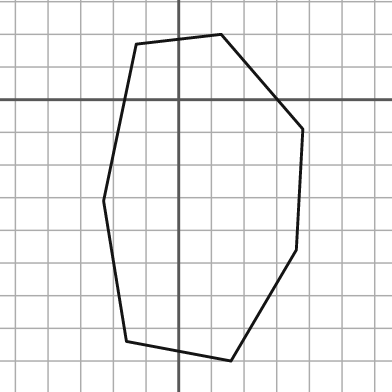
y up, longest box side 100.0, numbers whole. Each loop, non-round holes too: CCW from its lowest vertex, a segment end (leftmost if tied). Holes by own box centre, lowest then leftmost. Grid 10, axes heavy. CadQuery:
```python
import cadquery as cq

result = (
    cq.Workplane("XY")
    .moveTo(16.0, -80.0)
    .lineTo(36.0, -46.0)
    .lineTo(38.0, -9.0)
    .lineTo(13.0, 20.0)
    .lineTo(-13.0, 17.0)
    .lineTo(-23.0, -31.0)
    .lineTo(-16.0, -74.0)
    .close()
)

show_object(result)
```